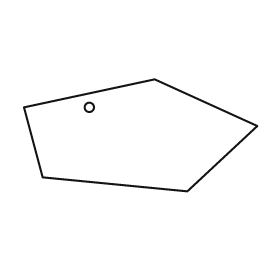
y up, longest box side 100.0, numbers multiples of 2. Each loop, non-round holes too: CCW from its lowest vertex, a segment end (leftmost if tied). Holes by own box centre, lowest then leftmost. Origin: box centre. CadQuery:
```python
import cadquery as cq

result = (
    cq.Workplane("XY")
    .moveTo(20.0, -24.0)
    .lineTo(50.0, 4.0)
    .lineTo(6.0, 24.0)
    .lineTo(-50.0, 12.0)
    .lineTo(-42.0, -18.0)
    .close()
    .moveTo(-22.0, 12.0)
    .circle(2.0)
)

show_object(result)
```